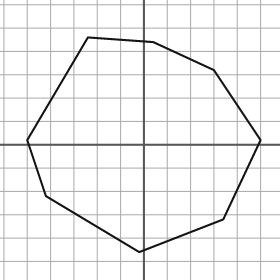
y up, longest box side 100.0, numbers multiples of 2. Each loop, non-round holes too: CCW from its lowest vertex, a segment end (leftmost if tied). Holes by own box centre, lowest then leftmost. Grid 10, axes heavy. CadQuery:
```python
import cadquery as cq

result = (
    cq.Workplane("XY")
    .moveTo(-2.0, -46.0)
    .lineTo(34.0, -32.0)
    .lineTo(50.0, 2.0)
    .lineTo(30.0, 32.0)
    .lineTo(4.0, 44.0)
    .lineTo(-24.0, 46.0)
    .lineTo(-50.0, 2.0)
    .lineTo(-42.0, -22.0)
    .close()
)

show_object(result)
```